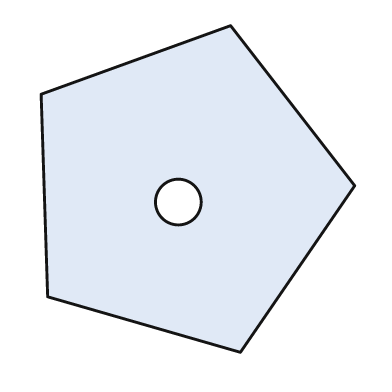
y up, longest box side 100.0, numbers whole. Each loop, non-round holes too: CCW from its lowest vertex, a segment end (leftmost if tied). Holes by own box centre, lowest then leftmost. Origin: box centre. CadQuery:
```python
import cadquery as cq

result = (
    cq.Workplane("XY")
    .moveTo(13.0, -50.0)
    .lineTo(48.0, 1.0)
    .lineTo(10.0, 50.0)
    .lineTo(-48.0, 29.0)
    .lineTo(-46.0, -33.0)
    .close()
    .moveTo(-6.0, -4.0)
    .circle(7.0)
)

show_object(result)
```